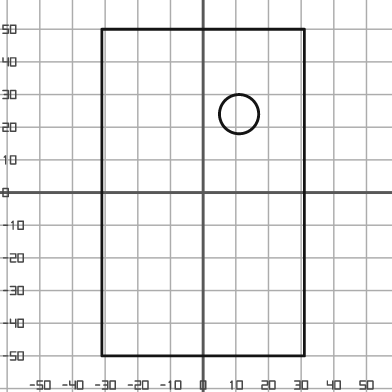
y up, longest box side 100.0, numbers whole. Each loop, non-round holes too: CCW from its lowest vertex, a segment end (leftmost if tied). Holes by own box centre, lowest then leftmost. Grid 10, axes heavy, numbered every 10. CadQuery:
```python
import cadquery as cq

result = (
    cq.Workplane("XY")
    .moveTo(-31.0, -50.0)
    .lineTo(31.0, -50.0)
    .lineTo(31.0, 50.0)
    .lineTo(-31.0, 50.0)
    .close()
    .moveTo(11.0, 24.0)
    .circle(6.0)
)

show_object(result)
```